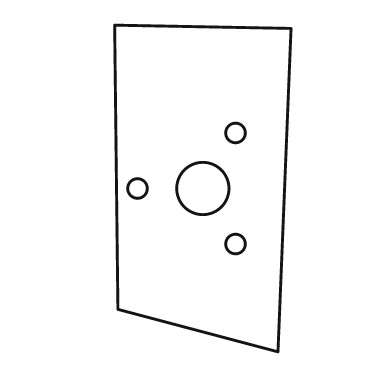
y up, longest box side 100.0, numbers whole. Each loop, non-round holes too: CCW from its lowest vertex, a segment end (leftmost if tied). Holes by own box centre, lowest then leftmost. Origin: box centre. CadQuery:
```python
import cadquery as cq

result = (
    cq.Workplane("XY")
    .moveTo(23.0, -50.0)
    .lineTo(27.0, 49.0)
    .lineTo(-27.0, 50.0)
    .lineTo(-26.0, -37.0)
    .close()
    .moveTo(10.0, -17.0)
    .circle(3.0)
    .moveTo(-20.0, 0.0)
    .circle(3.0)
    .moveTo(0.0, 0.0)
    .circle(8.0)
    .moveTo(10.0, 17.0)
    .circle(3.0)
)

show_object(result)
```